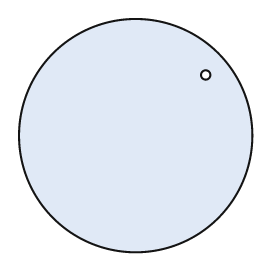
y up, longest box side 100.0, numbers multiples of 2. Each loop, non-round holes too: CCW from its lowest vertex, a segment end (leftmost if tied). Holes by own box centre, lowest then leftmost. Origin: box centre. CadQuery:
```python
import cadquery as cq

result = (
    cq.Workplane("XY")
    .moveTo(0.0, 0.0)
    .circle(50.0)
    .moveTo(30.0, 26.0)
    .circle(2.0)
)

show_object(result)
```